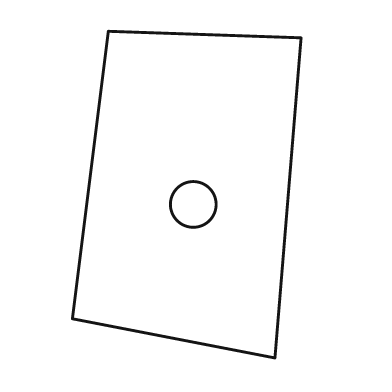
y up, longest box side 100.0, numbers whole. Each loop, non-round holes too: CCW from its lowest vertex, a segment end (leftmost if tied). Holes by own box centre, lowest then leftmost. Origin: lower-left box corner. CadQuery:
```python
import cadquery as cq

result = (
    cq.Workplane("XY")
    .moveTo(62.0, 0.0)
    .lineTo(70.0, 98.0)
    .lineTo(11.0, 100.0)
    .lineTo(0.0, 12.0)
    .close()
    .moveTo(37.0, 47.0)
    .circle(7.0)
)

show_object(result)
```